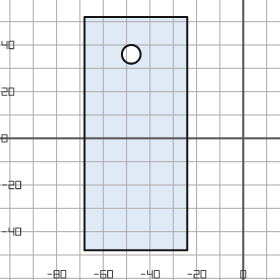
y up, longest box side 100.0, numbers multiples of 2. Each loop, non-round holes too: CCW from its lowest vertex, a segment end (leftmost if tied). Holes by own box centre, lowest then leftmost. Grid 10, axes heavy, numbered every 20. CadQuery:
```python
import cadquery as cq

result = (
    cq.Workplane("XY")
    .moveTo(-68.0, -48.0)
    .lineTo(-24.0, -48.0)
    .lineTo(-24.0, 52.0)
    .lineTo(-68.0, 52.0)
    .close()
    .moveTo(-48.0, 36.0)
    .circle(4.0)
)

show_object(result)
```